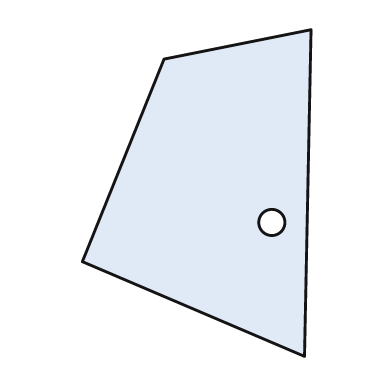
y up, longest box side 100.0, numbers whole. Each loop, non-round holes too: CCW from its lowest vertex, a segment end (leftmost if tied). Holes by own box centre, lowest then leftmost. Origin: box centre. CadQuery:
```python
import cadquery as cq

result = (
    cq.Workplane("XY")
    .moveTo(33.0, -50.0)
    .lineTo(35.0, 50.0)
    .lineTo(-10.0, 41.0)
    .lineTo(-35.0, -21.0)
    .close()
    .moveTo(23.0, -9.0)
    .circle(4.0)
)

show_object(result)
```